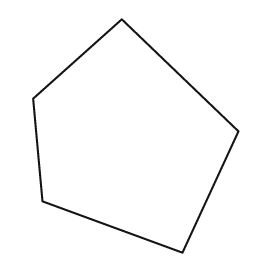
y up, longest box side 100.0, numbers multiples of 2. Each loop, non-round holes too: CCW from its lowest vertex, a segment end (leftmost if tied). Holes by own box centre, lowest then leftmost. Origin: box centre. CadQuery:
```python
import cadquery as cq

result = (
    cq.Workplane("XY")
    .moveTo(20.0, -50.0)
    .lineTo(44.0, 2.0)
    .lineTo(-6.0, 50.0)
    .lineTo(-44.0, 16.0)
    .lineTo(-40.0, -28.0)
    .close()
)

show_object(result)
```